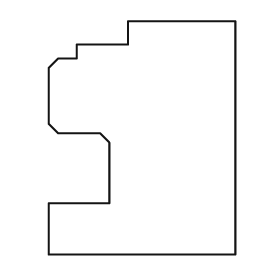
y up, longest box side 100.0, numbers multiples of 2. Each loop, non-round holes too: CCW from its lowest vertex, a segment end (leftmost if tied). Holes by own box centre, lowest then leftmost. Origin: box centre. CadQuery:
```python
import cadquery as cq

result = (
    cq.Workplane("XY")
    .moveTo(-40.0, -50.0)
    .lineTo(40.0, -50.0)
    .lineTo(40.0, 50.0)
    .lineTo(-6.0, 50.0)
    .lineTo(-6.0, 40.0)
    .lineTo(-28.0, 40.0)
    .lineTo(-28.0, 34.0)
    .lineTo(-36.0, 34.0)
    .lineTo(-40.0, 30.0)
    .lineTo(-40.0, 6.0)
    .lineTo(-36.0, 2.0)
    .lineTo(-18.0, 2.0)
    .lineTo(-14.0, -2.0)
    .lineTo(-14.0, -28.0)
    .lineTo(-40.0, -28.0)
    .close()
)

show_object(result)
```